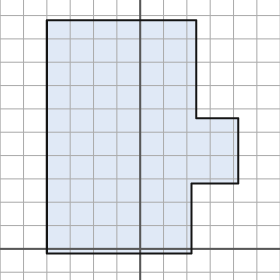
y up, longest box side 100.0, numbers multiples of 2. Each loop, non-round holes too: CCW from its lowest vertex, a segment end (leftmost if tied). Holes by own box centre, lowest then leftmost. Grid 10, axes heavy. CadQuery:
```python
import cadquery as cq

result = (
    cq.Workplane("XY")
    .moveTo(-40.0, -2.0)
    .lineTo(22.0, -2.0)
    .lineTo(22.0, 28.0)
    .lineTo(42.0, 28.0)
    .lineTo(42.0, 56.0)
    .lineTo(24.0, 56.0)
    .lineTo(24.0, 98.0)
    .lineTo(-40.0, 98.0)
    .close()
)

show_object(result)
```